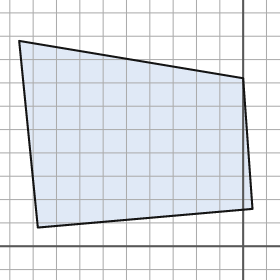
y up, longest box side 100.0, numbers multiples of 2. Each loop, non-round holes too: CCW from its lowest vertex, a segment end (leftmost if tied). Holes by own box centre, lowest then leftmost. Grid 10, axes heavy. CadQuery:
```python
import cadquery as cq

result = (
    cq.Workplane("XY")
    .moveTo(-88.0, 8.0)
    .lineTo(4.0, 16.0)
    .lineTo(0.0, 72.0)
    .lineTo(-96.0, 88.0)
    .close()
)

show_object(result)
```